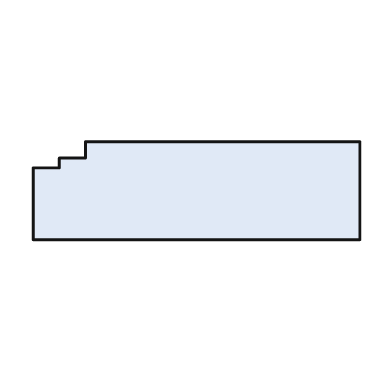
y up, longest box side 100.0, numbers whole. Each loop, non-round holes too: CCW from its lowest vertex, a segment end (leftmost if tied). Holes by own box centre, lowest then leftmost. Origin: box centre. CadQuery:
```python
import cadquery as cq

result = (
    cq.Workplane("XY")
    .moveTo(-50.0, -15.0)
    .lineTo(50.0, -15.0)
    .lineTo(50.0, 15.0)
    .lineTo(-34.0, 15.0)
    .lineTo(-34.0, 10.0)
    .lineTo(-42.0, 10.0)
    .lineTo(-42.0, 7.0)
    .lineTo(-50.0, 7.0)
    .close()
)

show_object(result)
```